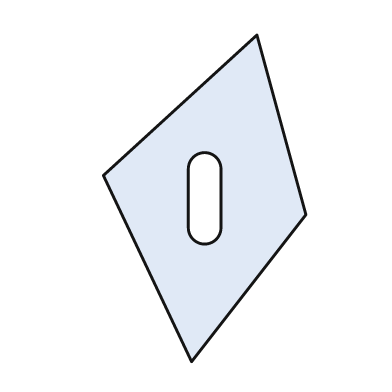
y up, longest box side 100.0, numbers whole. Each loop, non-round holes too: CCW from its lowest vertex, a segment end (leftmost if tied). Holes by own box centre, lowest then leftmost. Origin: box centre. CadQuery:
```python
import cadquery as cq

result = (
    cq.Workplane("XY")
    .moveTo(-4.0, -50.0)
    .lineTo(31.0, -5.0)
    .lineTo(16.0, 50.0)
    .lineTo(-31.0, 7.0)
    .close()
    .moveTo(-5.0, -9.0)
    .threePointArc((0.0, -14.0), (5.0, -9.0))
    .lineTo(5.0, 9.0)
    .threePointArc((0.0, 14.0), (-5.0, 9.0))
    .close()
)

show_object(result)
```